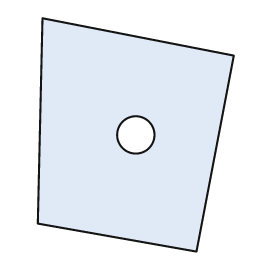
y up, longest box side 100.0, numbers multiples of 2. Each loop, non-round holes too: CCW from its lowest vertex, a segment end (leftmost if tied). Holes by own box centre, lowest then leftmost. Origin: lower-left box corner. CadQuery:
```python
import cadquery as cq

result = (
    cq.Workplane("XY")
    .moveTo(68.0, 0.0)
    .lineTo(84.0, 84.0)
    .lineTo(2.0, 100.0)
    .lineTo(0.0, 12.0)
    .close()
    .moveTo(42.0, 50.0)
    .circle(8.0)
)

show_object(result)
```